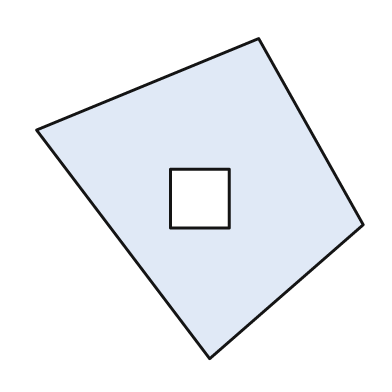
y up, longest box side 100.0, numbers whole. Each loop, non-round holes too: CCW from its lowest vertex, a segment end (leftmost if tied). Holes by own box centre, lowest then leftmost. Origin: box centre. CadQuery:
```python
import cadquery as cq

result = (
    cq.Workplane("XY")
    .moveTo(3.0, -49.0)
    .lineTo(50.0, -8.0)
    .lineTo(18.0, 49.0)
    .lineTo(-50.0, 21.0)
    .close()
    .moveTo(-9.0, -9.0)
    .lineTo(9.0, -9.0)
    .lineTo(9.0, 9.0)
    .lineTo(-9.0, 9.0)
    .close()
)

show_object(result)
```